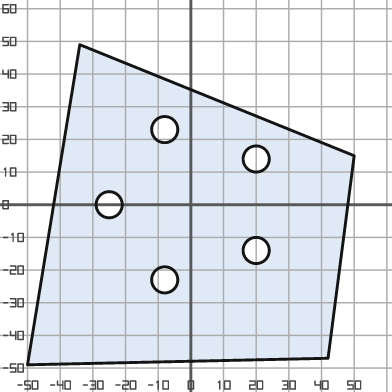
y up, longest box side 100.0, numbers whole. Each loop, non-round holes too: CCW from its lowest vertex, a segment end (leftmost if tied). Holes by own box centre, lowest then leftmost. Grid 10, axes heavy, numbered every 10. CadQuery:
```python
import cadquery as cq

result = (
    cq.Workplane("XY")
    .moveTo(-50.0, -49.0)
    .lineTo(42.0, -47.0)
    .lineTo(50.0, 15.0)
    .lineTo(-34.0, 49.0)
    .close()
    .moveTo(-8.0, -23.0)
    .circle(4.0)
    .moveTo(20.0, -14.0)
    .circle(4.0)
    .moveTo(-25.0, 0.0)
    .circle(4.0)
    .moveTo(20.0, 14.0)
    .circle(4.0)
    .moveTo(-8.0, 23.0)
    .circle(4.0)
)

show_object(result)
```